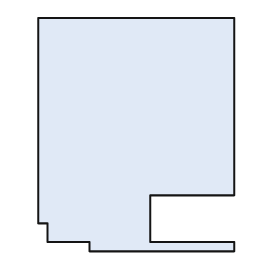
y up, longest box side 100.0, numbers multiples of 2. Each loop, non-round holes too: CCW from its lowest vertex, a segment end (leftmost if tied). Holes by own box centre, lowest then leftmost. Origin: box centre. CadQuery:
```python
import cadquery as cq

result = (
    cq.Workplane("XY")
    .moveTo(-20.0, -50.0)
    .lineTo(42.0, -50.0)
    .lineTo(42.0, -46.0)
    .lineTo(6.0, -46.0)
    .lineTo(6.0, -26.0)
    .lineTo(42.0, -26.0)
    .lineTo(42.0, 50.0)
    .lineTo(-42.0, 50.0)
    .lineTo(-42.0, -38.0)
    .lineTo(-38.0, -38.0)
    .lineTo(-38.0, -46.0)
    .lineTo(-20.0, -46.0)
    .close()
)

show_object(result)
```